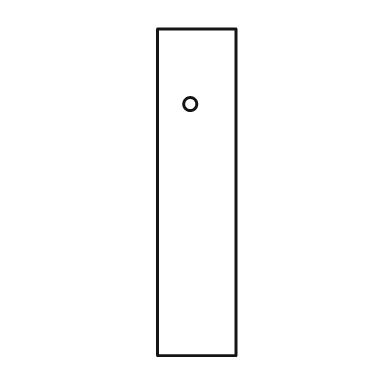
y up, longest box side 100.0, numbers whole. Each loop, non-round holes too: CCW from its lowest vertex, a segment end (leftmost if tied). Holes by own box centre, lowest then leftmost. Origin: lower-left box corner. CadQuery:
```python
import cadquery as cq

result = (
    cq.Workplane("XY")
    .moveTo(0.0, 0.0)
    .lineTo(24.0, 0.0)
    .lineTo(24.0, 100.0)
    .lineTo(0.0, 100.0)
    .close()
    .moveTo(10.0, 77.0)
    .circle(2.0)
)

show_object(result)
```